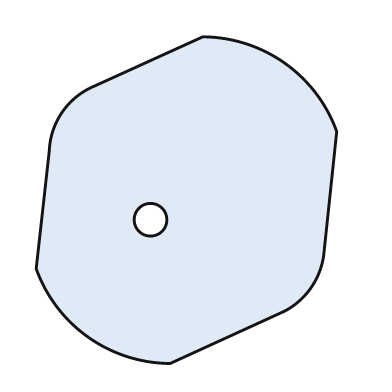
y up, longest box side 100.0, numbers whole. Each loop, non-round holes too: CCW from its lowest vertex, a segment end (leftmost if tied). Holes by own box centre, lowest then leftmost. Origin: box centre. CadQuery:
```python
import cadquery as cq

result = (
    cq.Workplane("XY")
    .moveTo(-5.0, -50.0)
    .lineTo(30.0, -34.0)
    .threePointArc((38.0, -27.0), (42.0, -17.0))
    .lineTo(46.0, 21.0)
    .threePointArc((30.0, 42.0), (5.0, 50.0))
    .lineTo(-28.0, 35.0)
    .threePointArc((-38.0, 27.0), (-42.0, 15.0))
    .lineTo(-46.0, -21.0)
    .threePointArc((-30.0, -42.0), (-5.0, -50.0))
    .close()
    .moveTo(-11.0, -6.0)
    .circle(5.0)
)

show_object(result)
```